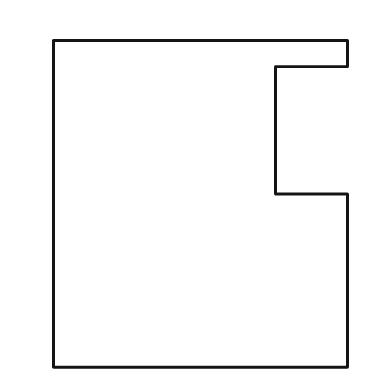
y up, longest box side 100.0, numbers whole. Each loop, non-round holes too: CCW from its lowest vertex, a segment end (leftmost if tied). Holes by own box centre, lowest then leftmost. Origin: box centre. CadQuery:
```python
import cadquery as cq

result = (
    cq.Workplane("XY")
    .moveTo(-45.0, -50.0)
    .lineTo(45.0, -50.0)
    .lineTo(45.0, 3.0)
    .lineTo(23.0, 3.0)
    .lineTo(23.0, 42.0)
    .lineTo(45.0, 42.0)
    .lineTo(45.0, 50.0)
    .lineTo(-45.0, 50.0)
    .close()
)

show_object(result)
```